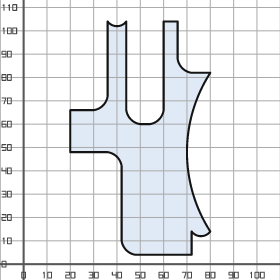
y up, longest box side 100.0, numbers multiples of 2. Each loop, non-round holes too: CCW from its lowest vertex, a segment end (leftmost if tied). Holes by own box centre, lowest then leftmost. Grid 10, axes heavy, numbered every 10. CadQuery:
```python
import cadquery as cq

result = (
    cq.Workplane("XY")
    .moveTo(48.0, 4.0)
    .lineTo(72.0, 4.0)
    .lineTo(72.0, 14.0)
    .threePointArc((76.0, 12.0), (80.0, 14.0))
    .threePointArc((70.0, 48.0), (80.0, 82.0))
    .lineTo(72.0, 82.0)
    .threePointArc((68.0, 84.0), (66.0, 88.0))
    .lineTo(66.0, 104.0)
    .lineTo(60.0, 104.0)
    .lineTo(60.0, 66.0)
    .threePointArc((58.0, 62.0), (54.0, 60.0))
    .lineTo(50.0, 60.0)
    .threePointArc((46.0, 62.0), (44.0, 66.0))
    .lineTo(44.0, 104.0)
    .threePointArc((40.0, 102.0), (36.0, 104.0))
    .lineTo(36.0, 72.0)
    .threePointArc((34.0, 68.0), (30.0, 66.0))
    .lineTo(20.0, 66.0)
    .lineTo(20.0, 48.0)
    .lineTo(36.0, 48.0)
    .threePointArc((40.0, 46.0), (42.0, 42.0))
    .lineTo(42.0, 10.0)
    .threePointArc((44.0, 6.0), (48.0, 4.0))
    .close()
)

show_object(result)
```